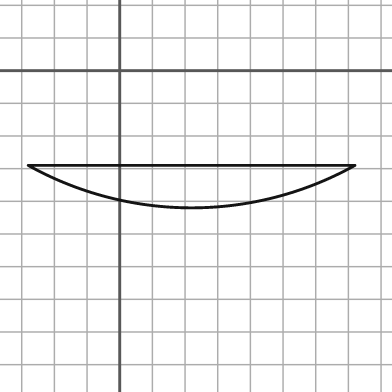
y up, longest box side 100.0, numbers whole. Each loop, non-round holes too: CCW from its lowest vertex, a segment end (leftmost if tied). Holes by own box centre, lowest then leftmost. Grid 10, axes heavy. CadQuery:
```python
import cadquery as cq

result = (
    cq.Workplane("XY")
    .moveTo(-28.0, -29.0)
    .threePointArc((22.0, -42.0), (72.0, -29.0))
    .close()
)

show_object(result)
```